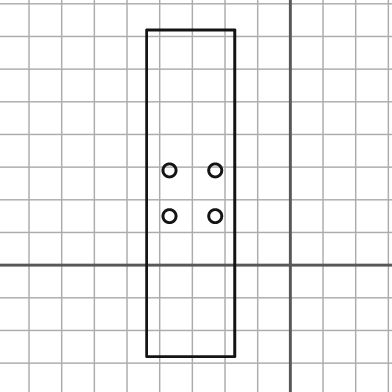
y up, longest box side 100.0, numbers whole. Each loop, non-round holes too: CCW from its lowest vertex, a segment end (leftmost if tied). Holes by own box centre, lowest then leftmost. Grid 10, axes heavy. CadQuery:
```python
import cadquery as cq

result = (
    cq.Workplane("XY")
    .moveTo(-44.0, -28.0)
    .lineTo(-17.0, -28.0)
    .lineTo(-17.0, 72.0)
    .lineTo(-44.0, 72.0)
    .close()
    .moveTo(-37.0, 15.0)
    .circle(2.0)
    .moveTo(-23.0, 15.0)
    .circle(2.0)
    .moveTo(-37.0, 29.0)
    .circle(2.0)
    .moveTo(-23.0, 29.0)
    .circle(2.0)
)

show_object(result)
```